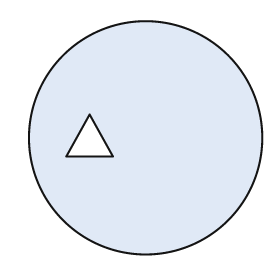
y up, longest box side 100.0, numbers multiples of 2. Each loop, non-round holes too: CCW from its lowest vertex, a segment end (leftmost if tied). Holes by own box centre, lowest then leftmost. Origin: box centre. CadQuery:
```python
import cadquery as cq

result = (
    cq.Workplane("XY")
    .moveTo(0.0, 0.0)
    .circle(50.0)
    .moveTo(-34.0, -8.0)
    .lineTo(-14.0, -8.0)
    .lineTo(-24.0, 10.0)
    .close()
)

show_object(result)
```